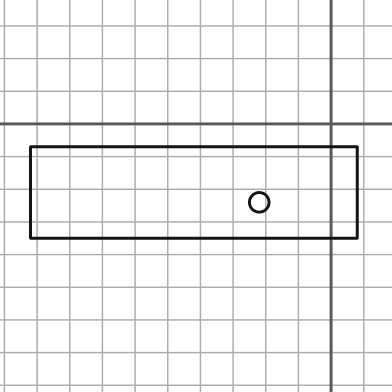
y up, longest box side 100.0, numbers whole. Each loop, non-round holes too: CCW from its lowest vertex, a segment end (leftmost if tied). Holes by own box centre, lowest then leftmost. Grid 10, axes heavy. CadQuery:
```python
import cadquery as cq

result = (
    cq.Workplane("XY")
    .moveTo(-92.0, -35.0)
    .lineTo(8.0, -35.0)
    .lineTo(8.0, -7.0)
    .lineTo(-92.0, -7.0)
    .close()
    .moveTo(-22.0, -24.0)
    .circle(3.0)
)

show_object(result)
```